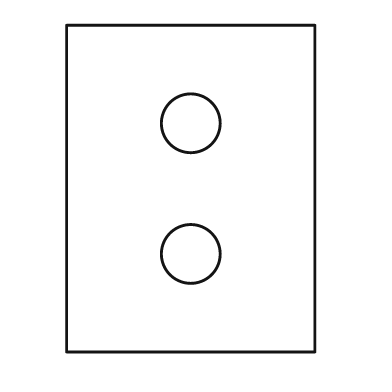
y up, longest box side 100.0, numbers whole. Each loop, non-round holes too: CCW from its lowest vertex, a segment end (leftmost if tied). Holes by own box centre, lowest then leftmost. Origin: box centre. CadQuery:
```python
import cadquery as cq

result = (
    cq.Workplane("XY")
    .moveTo(-38.0, -50.0)
    .lineTo(38.0, -50.0)
    .lineTo(38.0, 50.0)
    .lineTo(-38.0, 50.0)
    .close()
    .moveTo(0.0, -20.0)
    .circle(9.0)
    .moveTo(0.0, 20.0)
    .circle(9.0)
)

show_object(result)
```